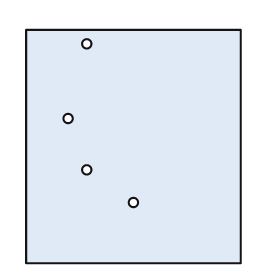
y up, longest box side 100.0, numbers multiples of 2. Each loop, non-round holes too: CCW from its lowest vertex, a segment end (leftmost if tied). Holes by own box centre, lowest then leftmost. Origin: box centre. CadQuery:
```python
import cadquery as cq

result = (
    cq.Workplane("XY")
    .moveTo(-46.0, -50.0)
    .lineTo(46.0, -50.0)
    .lineTo(46.0, 50.0)
    .lineTo(-46.0, 50.0)
    .close()
    .moveTo(0.0, -24.0)
    .circle(2.0)
    .moveTo(-20.0, -10.0)
    .circle(2.0)
    .moveTo(-28.0, 12.0)
    .circle(2.0)
    .moveTo(-20.0, 44.0)
    .circle(2.0)
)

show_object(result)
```